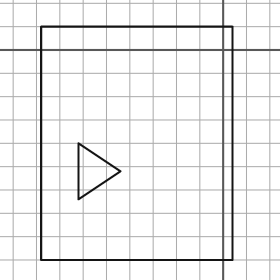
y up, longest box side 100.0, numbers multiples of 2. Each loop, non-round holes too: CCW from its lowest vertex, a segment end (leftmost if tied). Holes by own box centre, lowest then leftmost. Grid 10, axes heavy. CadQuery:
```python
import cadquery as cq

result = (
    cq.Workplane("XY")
    .moveTo(-78.0, -90.0)
    .lineTo(4.0, -90.0)
    .lineTo(4.0, 10.0)
    .lineTo(-78.0, 10.0)
    .close()
    .moveTo(-62.0, -64.0)
    .lineTo(-44.0, -52.0)
    .lineTo(-62.0, -40.0)
    .close()
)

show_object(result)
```